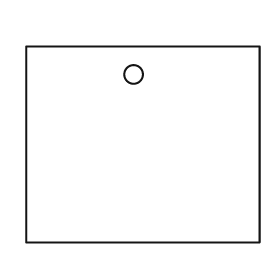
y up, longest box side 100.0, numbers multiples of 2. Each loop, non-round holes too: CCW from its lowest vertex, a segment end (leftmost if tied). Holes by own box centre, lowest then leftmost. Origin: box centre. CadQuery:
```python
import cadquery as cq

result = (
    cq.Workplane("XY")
    .moveTo(-50.0, -42.0)
    .lineTo(50.0, -42.0)
    .lineTo(50.0, 42.0)
    .lineTo(-50.0, 42.0)
    .close()
    .moveTo(-4.0, 30.0)
    .circle(4.0)
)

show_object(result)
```